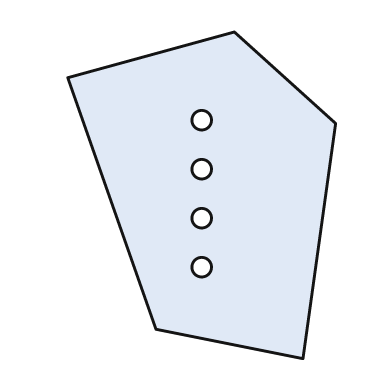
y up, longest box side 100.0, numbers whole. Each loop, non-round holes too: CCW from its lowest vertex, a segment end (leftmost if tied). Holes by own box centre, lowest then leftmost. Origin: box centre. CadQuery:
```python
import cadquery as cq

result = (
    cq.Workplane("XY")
    .moveTo(31.0, -50.0)
    .lineTo(41.0, 22.0)
    .lineTo(10.0, 50.0)
    .lineTo(-41.0, 36.0)
    .lineTo(-14.0, -41.0)
    .close()
    .moveTo(0.0, -22.0)
    .circle(3.0)
    .moveTo(0.0, -7.0)
    .circle(3.0)
    .moveTo(0.0, 8.0)
    .circle(3.0)
    .moveTo(0.0, 23.0)
    .circle(3.0)
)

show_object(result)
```